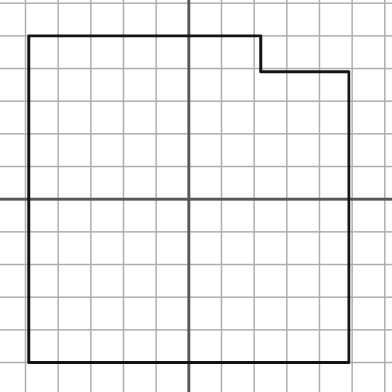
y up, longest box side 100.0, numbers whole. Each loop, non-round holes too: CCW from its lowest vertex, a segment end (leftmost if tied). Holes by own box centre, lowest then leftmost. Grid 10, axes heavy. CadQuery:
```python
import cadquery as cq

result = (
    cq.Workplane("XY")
    .moveTo(-49.0, -50.0)
    .lineTo(49.0, -50.0)
    .lineTo(49.0, 39.0)
    .lineTo(22.0, 39.0)
    .lineTo(22.0, 50.0)
    .lineTo(-49.0, 50.0)
    .close()
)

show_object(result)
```